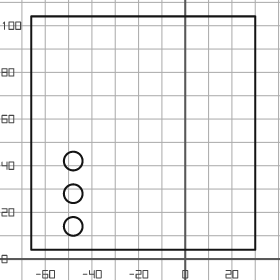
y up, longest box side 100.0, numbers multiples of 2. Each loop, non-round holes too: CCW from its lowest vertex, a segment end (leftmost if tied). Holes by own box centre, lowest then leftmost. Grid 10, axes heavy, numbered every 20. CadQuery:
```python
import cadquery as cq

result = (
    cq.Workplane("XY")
    .moveTo(-66.0, 4.0)
    .lineTo(30.0, 4.0)
    .lineTo(30.0, 104.0)
    .lineTo(-66.0, 104.0)
    .close()
    .moveTo(-48.0, 14.0)
    .circle(4.0)
    .moveTo(-48.0, 28.0)
    .circle(4.0)
    .moveTo(-48.0, 42.0)
    .circle(4.0)
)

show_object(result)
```